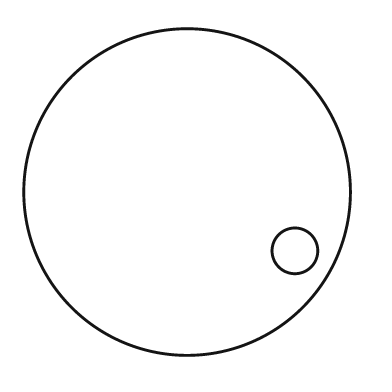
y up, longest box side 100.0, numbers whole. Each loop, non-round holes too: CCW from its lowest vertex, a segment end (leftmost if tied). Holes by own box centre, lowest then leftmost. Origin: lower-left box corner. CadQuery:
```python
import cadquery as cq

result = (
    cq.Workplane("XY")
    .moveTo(50.0, 50.0)
    .circle(50.0)
    .moveTo(83.0, 32.0)
    .circle(7.0)
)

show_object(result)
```